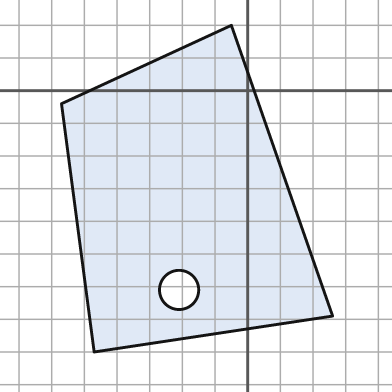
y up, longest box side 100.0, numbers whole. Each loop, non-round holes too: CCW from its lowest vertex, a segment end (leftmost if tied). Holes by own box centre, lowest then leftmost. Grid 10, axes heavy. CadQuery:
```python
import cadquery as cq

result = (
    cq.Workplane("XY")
    .moveTo(-47.0, -80.0)
    .lineTo(26.0, -69.0)
    .lineTo(-5.0, 20.0)
    .lineTo(-57.0, -4.0)
    .close()
    .moveTo(-21.0, -61.0)
    .circle(6.0)
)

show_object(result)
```